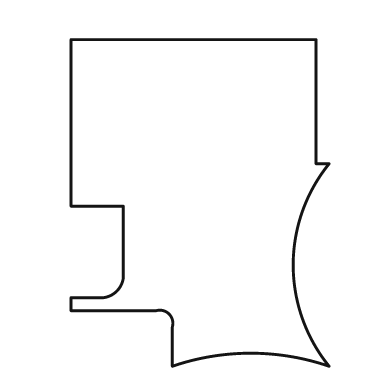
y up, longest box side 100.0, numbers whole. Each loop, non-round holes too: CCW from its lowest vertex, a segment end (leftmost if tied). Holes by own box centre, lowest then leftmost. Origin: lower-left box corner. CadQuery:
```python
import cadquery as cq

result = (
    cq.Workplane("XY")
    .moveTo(31.0, 0.0)
    .threePointArc((55.0, 4.0), (79.0, 0.0))
    .threePointArc((68.0, 31.0), (79.0, 62.0))
    .lineTo(75.0, 62.0)
    .lineTo(75.0, 100.0)
    .lineTo(0.0, 100.0)
    .lineTo(0.0, 49.0)
    .lineTo(16.0, 49.0)
    .lineTo(16.0, 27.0)
    .threePointArc((14.0, 23.0), (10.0, 21.0))
    .lineTo(0.0, 21.0)
    .lineTo(0.0, 17.0)
    .lineTo(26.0, 17.0)
    .threePointArc((30.0, 16.0), (31.0, 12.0))
    .close()
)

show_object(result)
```